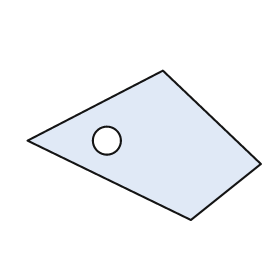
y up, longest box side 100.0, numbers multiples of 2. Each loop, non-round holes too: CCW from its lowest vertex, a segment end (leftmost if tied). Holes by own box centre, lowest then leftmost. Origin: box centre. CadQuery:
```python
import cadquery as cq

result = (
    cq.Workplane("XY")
    .moveTo(20.0, -32.0)
    .lineTo(50.0, -8.0)
    .lineTo(8.0, 32.0)
    .lineTo(-50.0, 2.0)
    .close()
    .moveTo(-16.0, 2.0)
    .circle(6.0)
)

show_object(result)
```